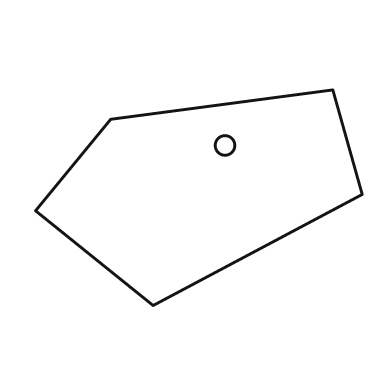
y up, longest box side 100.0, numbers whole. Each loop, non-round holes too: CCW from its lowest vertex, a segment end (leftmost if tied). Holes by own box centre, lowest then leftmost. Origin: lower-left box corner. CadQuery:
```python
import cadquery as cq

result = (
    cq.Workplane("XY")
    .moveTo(36.0, 0.0)
    .lineTo(100.0, 34.0)
    .lineTo(91.0, 66.0)
    .lineTo(23.0, 57.0)
    .lineTo(0.0, 29.0)
    .close()
    .moveTo(58.0, 49.0)
    .circle(3.0)
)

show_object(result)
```